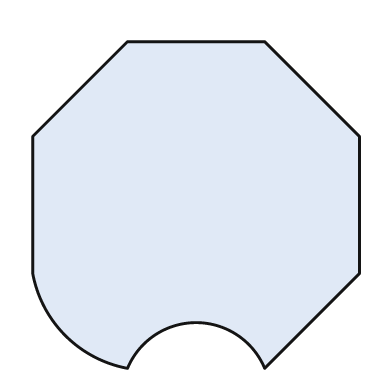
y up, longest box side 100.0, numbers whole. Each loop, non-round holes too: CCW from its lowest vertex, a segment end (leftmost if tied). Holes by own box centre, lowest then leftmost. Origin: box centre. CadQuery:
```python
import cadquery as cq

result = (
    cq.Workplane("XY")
    .moveTo(-21.0, -50.0)
    .threePointArc((0.0, -36.0), (21.0, -50.0))
    .lineTo(50.0, -21.0)
    .lineTo(50.0, 21.0)
    .lineTo(21.0, 50.0)
    .lineTo(-21.0, 50.0)
    .lineTo(-50.0, 21.0)
    .lineTo(-50.0, -21.0)
    .threePointArc((-40.0, -40.0), (-21.0, -50.0))
    .close()
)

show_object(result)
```